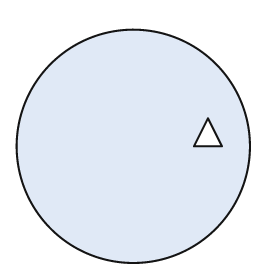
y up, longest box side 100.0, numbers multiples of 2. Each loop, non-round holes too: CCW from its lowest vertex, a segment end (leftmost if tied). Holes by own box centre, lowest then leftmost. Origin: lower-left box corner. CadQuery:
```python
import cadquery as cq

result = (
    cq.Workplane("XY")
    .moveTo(50.0, 50.0)
    .circle(50.0)
    .moveTo(76.0, 50.0)
    .lineTo(88.0, 50.0)
    .lineTo(82.0, 62.0)
    .close()
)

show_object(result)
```